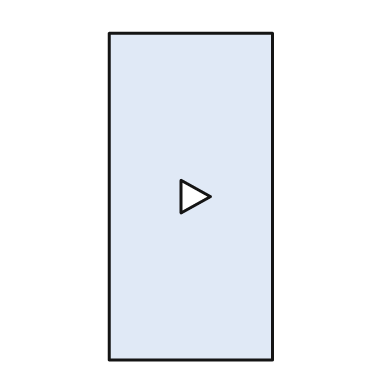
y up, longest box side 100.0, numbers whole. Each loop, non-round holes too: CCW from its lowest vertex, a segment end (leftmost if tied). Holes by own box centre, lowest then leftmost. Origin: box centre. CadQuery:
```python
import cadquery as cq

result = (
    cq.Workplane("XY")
    .moveTo(-25.0, -50.0)
    .lineTo(25.0, -50.0)
    .lineTo(25.0, 50.0)
    .lineTo(-25.0, 50.0)
    .close()
    .moveTo(-3.0, -5.0)
    .lineTo(6.0, 0.0)
    .lineTo(-3.0, 5.0)
    .close()
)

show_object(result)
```